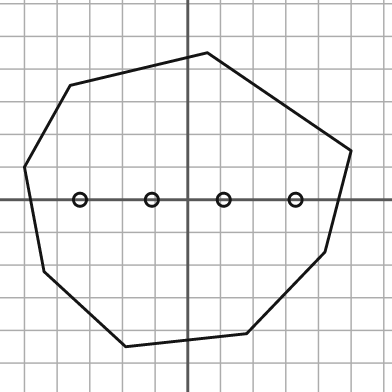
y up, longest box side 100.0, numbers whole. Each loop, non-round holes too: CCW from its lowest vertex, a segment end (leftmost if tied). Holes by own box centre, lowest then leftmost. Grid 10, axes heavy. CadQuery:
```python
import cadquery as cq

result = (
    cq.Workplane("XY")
    .moveTo(-19.0, -45.0)
    .lineTo(18.0, -41.0)
    .lineTo(42.0, -16.0)
    .lineTo(50.0, 15.0)
    .lineTo(6.0, 45.0)
    .lineTo(-36.0, 35.0)
    .lineTo(-50.0, 10.0)
    .lineTo(-44.0, -22.0)
    .close()
    .moveTo(-33.0, 0.0)
    .circle(2.0)
    .moveTo(-11.0, 0.0)
    .circle(2.0)
    .moveTo(11.0, 0.0)
    .circle(2.0)
    .moveTo(33.0, 0.0)
    .circle(2.0)
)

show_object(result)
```